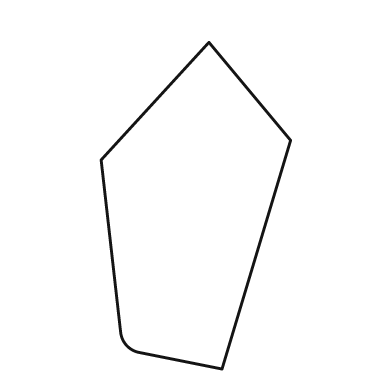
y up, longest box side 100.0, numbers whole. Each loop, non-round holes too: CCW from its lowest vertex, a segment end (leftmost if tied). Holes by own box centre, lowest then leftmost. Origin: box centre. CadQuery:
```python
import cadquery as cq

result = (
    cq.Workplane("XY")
    .moveTo(8.0, -50.0)
    .lineTo(29.0, 20.0)
    .lineTo(4.0, 50.0)
    .lineTo(-29.0, 14.0)
    .lineTo(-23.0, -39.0)
    .threePointArc((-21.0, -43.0), (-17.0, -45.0))
    .close()
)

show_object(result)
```